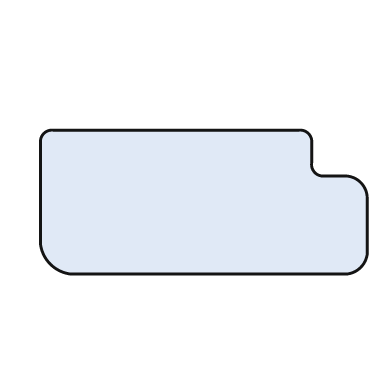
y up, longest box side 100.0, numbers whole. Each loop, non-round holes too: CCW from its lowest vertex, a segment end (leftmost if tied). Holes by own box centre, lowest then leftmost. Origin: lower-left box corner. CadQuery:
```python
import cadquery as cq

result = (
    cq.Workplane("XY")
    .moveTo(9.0, 0.0)
    .lineTo(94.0, 0.0)
    .threePointArc((98.0, 2.0), (100.0, 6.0))
    .lineTo(100.0, 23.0)
    .threePointArc((98.0, 28.0), (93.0, 30.0))
    .lineTo(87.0, 30.0)
    .threePointArc((84.0, 31.0), (83.0, 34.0))
    .lineTo(83.0, 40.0)
    .threePointArc((82.0, 43.0), (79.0, 44.0))
    .lineTo(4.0, 44.0)
    .threePointArc((1.0, 43.0), (0.0, 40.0))
    .lineTo(0.0, 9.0)
    .threePointArc((3.0, 3.0), (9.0, 0.0))
    .close()
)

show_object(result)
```